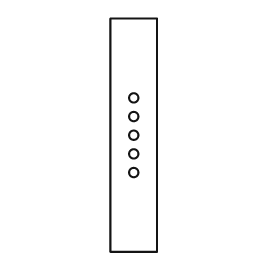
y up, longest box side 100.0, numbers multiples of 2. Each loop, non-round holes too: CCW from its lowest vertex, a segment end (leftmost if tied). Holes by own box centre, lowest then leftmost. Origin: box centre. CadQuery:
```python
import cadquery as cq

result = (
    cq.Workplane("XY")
    .moveTo(-10.0, -50.0)
    .lineTo(10.0, -50.0)
    .lineTo(10.0, 50.0)
    .lineTo(-10.0, 50.0)
    .close()
    .moveTo(0.0, -16.0)
    .circle(2.0)
    .moveTo(0.0, -8.0)
    .circle(2.0)
    .moveTo(0.0, 0.0)
    .circle(2.0)
    .moveTo(0.0, 8.0)
    .circle(2.0)
    .moveTo(0.0, 16.0)
    .circle(2.0)
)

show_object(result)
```